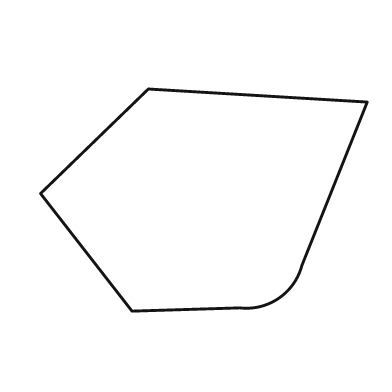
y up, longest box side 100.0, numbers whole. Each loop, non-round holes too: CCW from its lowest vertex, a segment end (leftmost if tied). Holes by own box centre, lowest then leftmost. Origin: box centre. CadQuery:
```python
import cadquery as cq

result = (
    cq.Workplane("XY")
    .moveTo(-22.0, -34.0)
    .lineTo(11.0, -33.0)
    .threePointArc((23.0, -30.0), (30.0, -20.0))
    .lineTo(50.0, 30.0)
    .lineTo(-17.0, 34.0)
    .lineTo(-50.0, 2.0)
    .close()
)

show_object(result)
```